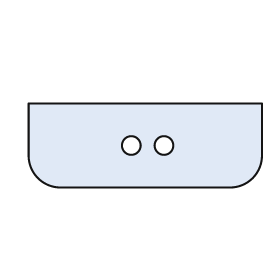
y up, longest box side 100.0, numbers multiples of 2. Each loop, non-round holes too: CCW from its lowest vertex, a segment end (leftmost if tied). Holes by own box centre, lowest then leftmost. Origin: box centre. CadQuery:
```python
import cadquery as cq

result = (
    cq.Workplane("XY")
    .moveTo(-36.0, -18.0)
    .lineTo(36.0, -18.0)
    .threePointArc((46.0, -14.0), (50.0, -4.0))
    .lineTo(50.0, 18.0)
    .lineTo(-50.0, 18.0)
    .lineTo(-50.0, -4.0)
    .threePointArc((-46.0, -14.0), (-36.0, -18.0))
    .close()
    .moveTo(-6.0, 0.0)
    .circle(4.0)
    .moveTo(8.0, 0.0)
    .circle(4.0)
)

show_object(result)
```